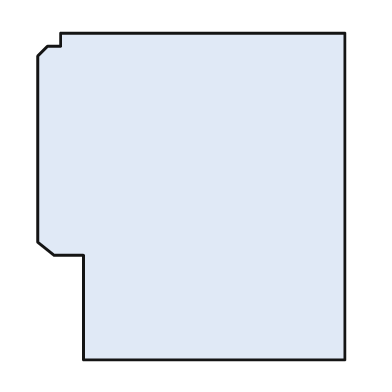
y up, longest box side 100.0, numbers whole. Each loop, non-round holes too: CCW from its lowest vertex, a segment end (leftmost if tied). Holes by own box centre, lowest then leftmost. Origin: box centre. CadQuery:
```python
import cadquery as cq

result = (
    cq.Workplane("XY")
    .moveTo(-33.0, -50.0)
    .lineTo(47.0, -50.0)
    .lineTo(47.0, 50.0)
    .lineTo(-40.0, 50.0)
    .lineTo(-40.0, 46.0)
    .lineTo(-44.0, 46.0)
    .lineTo(-47.0, 43.0)
    .lineTo(-47.0, -14.0)
    .lineTo(-42.0, -18.0)
    .lineTo(-33.0, -18.0)
    .close()
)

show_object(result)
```